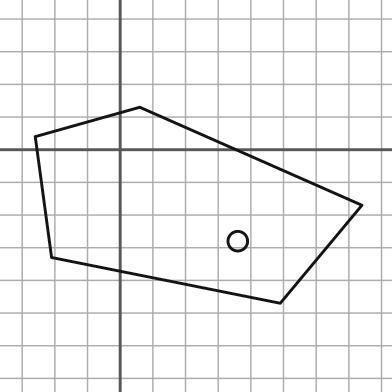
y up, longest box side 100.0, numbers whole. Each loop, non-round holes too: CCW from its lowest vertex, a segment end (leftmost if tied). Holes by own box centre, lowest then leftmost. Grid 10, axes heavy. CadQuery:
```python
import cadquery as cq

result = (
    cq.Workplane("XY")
    .moveTo(49.0, -47.0)
    .lineTo(74.0, -17.0)
    .lineTo(6.0, 13.0)
    .lineTo(-26.0, 4.0)
    .lineTo(-21.0, -33.0)
    .close()
    .moveTo(36.0, -28.0)
    .circle(3.0)
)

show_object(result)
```